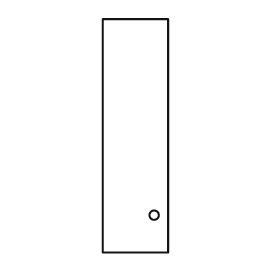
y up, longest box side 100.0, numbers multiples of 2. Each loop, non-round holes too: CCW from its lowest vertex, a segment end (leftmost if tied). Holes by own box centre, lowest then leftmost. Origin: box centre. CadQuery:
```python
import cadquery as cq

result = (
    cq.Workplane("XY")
    .moveTo(-14.0, -50.0)
    .lineTo(14.0, -50.0)
    .lineTo(14.0, 50.0)
    .lineTo(-14.0, 50.0)
    .close()
    .moveTo(8.0, -34.0)
    .circle(2.0)
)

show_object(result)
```